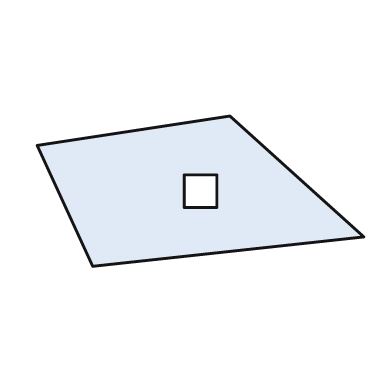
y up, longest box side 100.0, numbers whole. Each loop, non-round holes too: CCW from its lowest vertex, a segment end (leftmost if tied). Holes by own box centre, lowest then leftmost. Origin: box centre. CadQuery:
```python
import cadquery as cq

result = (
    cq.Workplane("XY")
    .moveTo(-33.0, -23.0)
    .lineTo(50.0, -14.0)
    .lineTo(9.0, 23.0)
    .lineTo(-50.0, 14.0)
    .close()
    .moveTo(-5.0, -5.0)
    .lineTo(5.0, -5.0)
    .lineTo(5.0, 5.0)
    .lineTo(-5.0, 5.0)
    .close()
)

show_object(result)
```